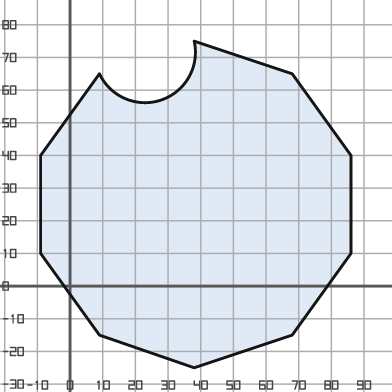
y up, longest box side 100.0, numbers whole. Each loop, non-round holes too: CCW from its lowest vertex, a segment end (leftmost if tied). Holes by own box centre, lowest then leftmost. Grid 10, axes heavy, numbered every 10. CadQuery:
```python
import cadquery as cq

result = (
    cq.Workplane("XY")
    .moveTo(38.0, -25.0)
    .lineTo(68.0, -15.0)
    .lineTo(86.0, 10.0)
    .lineTo(86.0, 40.0)
    .lineTo(68.0, 65.0)
    .lineTo(38.0, 75.0)
    .threePointArc((28.0, 57.0), (9.0, 65.0))
    .lineTo(-9.0, 40.0)
    .lineTo(-9.0, 10.0)
    .lineTo(9.0, -15.0)
    .close()
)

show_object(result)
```